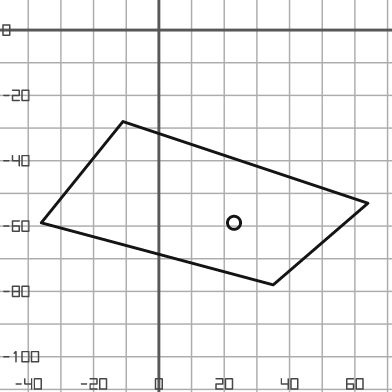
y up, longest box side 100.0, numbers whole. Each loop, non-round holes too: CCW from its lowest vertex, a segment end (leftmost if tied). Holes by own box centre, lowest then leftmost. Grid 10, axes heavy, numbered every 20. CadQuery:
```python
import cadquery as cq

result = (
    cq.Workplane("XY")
    .moveTo(35.0, -78.0)
    .lineTo(64.0, -53.0)
    .lineTo(-11.0, -28.0)
    .lineTo(-36.0, -59.0)
    .close()
    .moveTo(23.0, -59.0)
    .circle(2.0)
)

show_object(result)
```